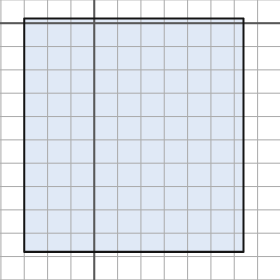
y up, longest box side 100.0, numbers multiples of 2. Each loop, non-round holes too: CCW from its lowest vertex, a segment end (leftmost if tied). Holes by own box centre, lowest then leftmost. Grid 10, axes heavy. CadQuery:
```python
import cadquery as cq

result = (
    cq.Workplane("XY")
    .moveTo(-30.0, -98.0)
    .lineTo(64.0, -98.0)
    .lineTo(64.0, 2.0)
    .lineTo(-30.0, 2.0)
    .close()
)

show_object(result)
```